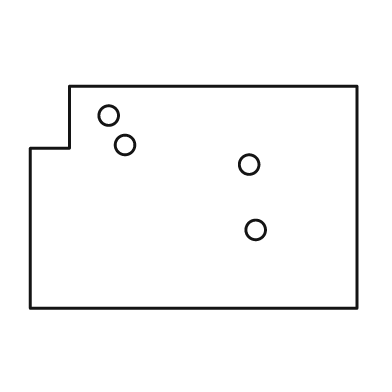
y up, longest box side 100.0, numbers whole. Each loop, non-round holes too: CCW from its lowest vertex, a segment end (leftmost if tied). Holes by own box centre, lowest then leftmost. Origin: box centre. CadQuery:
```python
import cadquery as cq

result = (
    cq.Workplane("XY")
    .moveTo(-50.0, -34.0)
    .lineTo(50.0, -34.0)
    .lineTo(50.0, 34.0)
    .lineTo(-38.0, 34.0)
    .lineTo(-38.0, 15.0)
    .lineTo(-50.0, 15.0)
    .close()
    .moveTo(19.0, -10.0)
    .circle(3.0)
    .moveTo(17.0, 10.0)
    .circle(3.0)
    .moveTo(-21.0, 16.0)
    .circle(3.0)
    .moveTo(-26.0, 25.0)
    .circle(3.0)
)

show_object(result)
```